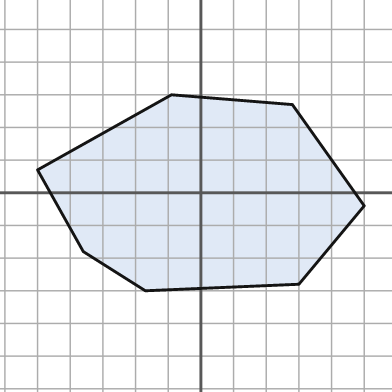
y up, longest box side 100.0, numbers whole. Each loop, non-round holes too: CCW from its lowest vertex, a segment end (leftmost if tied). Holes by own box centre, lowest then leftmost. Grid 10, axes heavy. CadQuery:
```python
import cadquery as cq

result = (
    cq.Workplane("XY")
    .moveTo(-17.0, -30.0)
    .lineTo(30.0, -28.0)
    .lineTo(50.0, -4.0)
    .lineTo(28.0, 27.0)
    .lineTo(-9.0, 30.0)
    .lineTo(-50.0, 7.0)
    .lineTo(-36.0, -18.0)
    .close()
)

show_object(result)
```